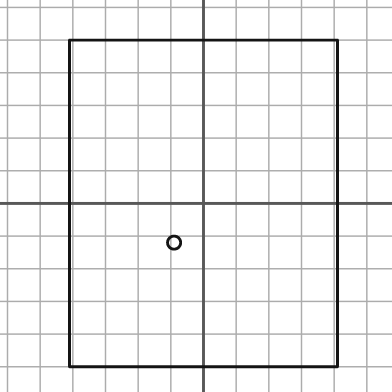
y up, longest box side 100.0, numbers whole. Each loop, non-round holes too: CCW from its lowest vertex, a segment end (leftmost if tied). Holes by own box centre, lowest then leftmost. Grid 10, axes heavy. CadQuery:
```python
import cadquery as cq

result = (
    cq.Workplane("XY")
    .moveTo(-41.0, -50.0)
    .lineTo(41.0, -50.0)
    .lineTo(41.0, 50.0)
    .lineTo(-41.0, 50.0)
    .close()
    .moveTo(-9.0, -12.0)
    .circle(2.0)
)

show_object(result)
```